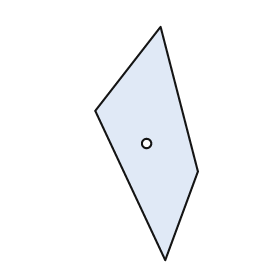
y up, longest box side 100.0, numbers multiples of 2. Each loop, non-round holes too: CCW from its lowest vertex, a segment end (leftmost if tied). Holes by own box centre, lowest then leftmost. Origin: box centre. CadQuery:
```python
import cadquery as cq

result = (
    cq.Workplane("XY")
    .moveTo(8.0, -50.0)
    .lineTo(22.0, -12.0)
    .lineTo(6.0, 50.0)
    .lineTo(-22.0, 14.0)
    .close()
    .moveTo(0.0, 0.0)
    .circle(2.0)
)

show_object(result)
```